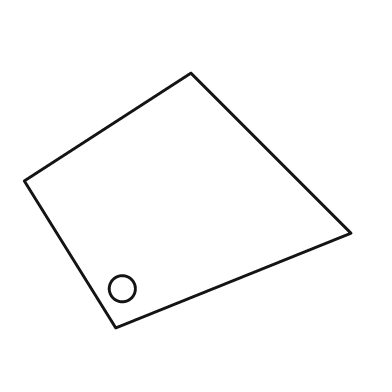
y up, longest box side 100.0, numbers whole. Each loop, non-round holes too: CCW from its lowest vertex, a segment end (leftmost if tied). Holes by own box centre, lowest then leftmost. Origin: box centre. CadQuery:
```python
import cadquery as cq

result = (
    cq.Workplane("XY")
    .moveTo(-22.0, -39.0)
    .lineTo(50.0, -10.0)
    .lineTo(1.0, 39.0)
    .lineTo(-50.0, 6.0)
    .close()
    .moveTo(-20.0, -27.0)
    .circle(4.0)
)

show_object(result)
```